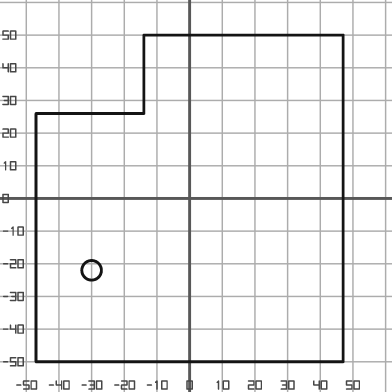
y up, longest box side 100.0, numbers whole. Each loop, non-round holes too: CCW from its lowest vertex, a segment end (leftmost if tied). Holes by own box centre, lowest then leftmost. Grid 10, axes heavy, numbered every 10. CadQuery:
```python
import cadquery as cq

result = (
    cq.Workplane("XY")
    .moveTo(-47.0, -50.0)
    .lineTo(47.0, -50.0)
    .lineTo(47.0, 50.0)
    .lineTo(-14.0, 50.0)
    .lineTo(-14.0, 26.0)
    .lineTo(-47.0, 26.0)
    .close()
    .moveTo(-30.0, -22.0)
    .circle(3.0)
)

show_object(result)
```